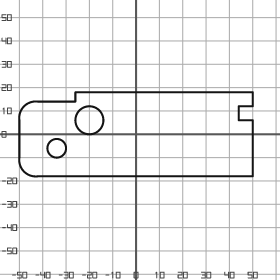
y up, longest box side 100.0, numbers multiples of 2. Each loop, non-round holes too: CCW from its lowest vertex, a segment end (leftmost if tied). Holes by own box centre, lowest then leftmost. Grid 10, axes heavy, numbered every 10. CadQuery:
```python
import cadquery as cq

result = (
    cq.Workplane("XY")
    .moveTo(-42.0, -18.0)
    .lineTo(50.0, -18.0)
    .lineTo(50.0, 6.0)
    .lineTo(44.0, 6.0)
    .lineTo(44.0, 12.0)
    .lineTo(50.0, 12.0)
    .lineTo(50.0, 18.0)
    .lineTo(-26.0, 18.0)
    .lineTo(-26.0, 14.0)
    .lineTo(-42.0, 14.0)
    .threePointArc((-48.0, 12.0), (-50.0, 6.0))
    .lineTo(-50.0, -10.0)
    .threePointArc((-48.0, -16.0), (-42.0, -18.0))
    .close()
    .moveTo(-34.0, -6.0)
    .circle(4.0)
    .moveTo(-20.0, 6.0)
    .circle(6.0)
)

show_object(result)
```